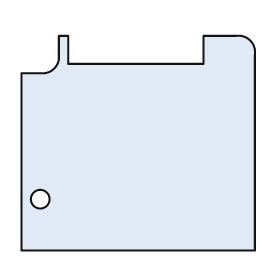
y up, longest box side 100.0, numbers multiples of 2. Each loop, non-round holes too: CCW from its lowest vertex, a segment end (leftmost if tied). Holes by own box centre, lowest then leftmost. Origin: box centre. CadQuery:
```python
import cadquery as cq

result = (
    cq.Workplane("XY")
    .moveTo(-50.0, -46.0)
    .lineTo(50.0, -46.0)
    .lineTo(50.0, 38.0)
    .threePointArc((48.0, 44.0), (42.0, 46.0))
    .lineTo(28.0, 46.0)
    .lineTo(28.0, 34.0)
    .lineTo(-30.0, 34.0)
    .lineTo(-30.0, 46.0)
    .lineTo(-34.0, 46.0)
    .lineTo(-34.0, 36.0)
    .threePointArc((-36.0, 32.0), (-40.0, 30.0))
    .lineTo(-50.0, 30.0)
    .close()
    .moveTo(-42.0, -24.0)
    .circle(4.0)
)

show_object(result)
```